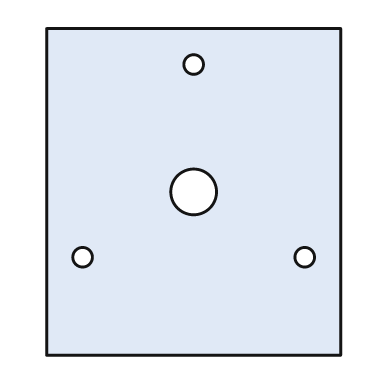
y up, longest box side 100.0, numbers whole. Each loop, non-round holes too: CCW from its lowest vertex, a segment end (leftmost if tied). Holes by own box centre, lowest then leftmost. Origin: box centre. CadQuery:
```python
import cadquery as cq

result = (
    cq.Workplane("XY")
    .moveTo(-45.0, -50.0)
    .lineTo(45.0, -50.0)
    .lineTo(45.0, 50.0)
    .lineTo(-45.0, 50.0)
    .close()
    .moveTo(-34.0, -20.0)
    .circle(3.0)
    .moveTo(34.0, -20.0)
    .circle(3.0)
    .moveTo(0.0, 0.0)
    .circle(7.0)
    .moveTo(0.0, 39.0)
    .circle(3.0)
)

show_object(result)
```